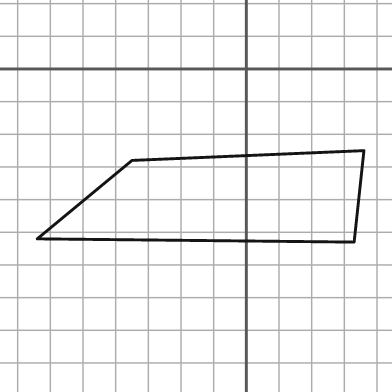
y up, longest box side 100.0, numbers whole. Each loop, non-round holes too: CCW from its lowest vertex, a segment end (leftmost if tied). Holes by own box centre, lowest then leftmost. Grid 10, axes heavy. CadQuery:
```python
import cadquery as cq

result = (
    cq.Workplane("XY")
    .moveTo(33.0, -53.0)
    .lineTo(36.0, -25.0)
    .lineTo(-35.0, -28.0)
    .lineTo(-64.0, -52.0)
    .close()
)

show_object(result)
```